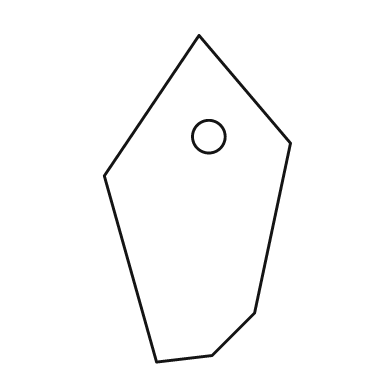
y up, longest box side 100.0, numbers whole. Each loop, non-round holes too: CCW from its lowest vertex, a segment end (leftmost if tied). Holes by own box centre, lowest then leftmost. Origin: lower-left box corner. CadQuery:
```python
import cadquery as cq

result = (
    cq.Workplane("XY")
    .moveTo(16.0, 0.0)
    .lineTo(33.0, 2.0)
    .lineTo(46.0, 15.0)
    .lineTo(57.0, 67.0)
    .lineTo(29.0, 100.0)
    .lineTo(0.0, 57.0)
    .close()
    .moveTo(32.0, 69.0)
    .circle(5.0)
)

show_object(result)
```